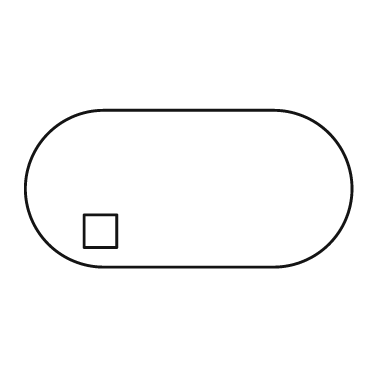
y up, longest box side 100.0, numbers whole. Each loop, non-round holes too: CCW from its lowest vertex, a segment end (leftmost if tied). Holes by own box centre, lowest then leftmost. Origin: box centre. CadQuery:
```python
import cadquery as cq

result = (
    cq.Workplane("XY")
    .moveTo(-26.0, -24.0)
    .lineTo(26.0, -24.0)
    .threePointArc((50.0, 0.0), (26.0, 24.0))
    .lineTo(-26.0, 24.0)
    .threePointArc((-50.0, 0.0), (-26.0, -24.0))
    .close()
    .moveTo(-32.0, -18.0)
    .lineTo(-22.0, -18.0)
    .lineTo(-22.0, -8.0)
    .lineTo(-32.0, -8.0)
    .close()
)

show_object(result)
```